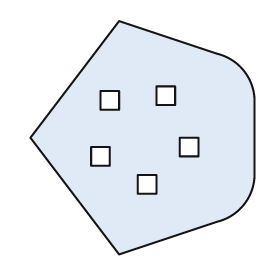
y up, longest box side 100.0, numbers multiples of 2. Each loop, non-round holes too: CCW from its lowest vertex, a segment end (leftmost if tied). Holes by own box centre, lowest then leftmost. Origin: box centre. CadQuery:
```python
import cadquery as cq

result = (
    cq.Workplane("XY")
    .moveTo(-10.0, -50.0)
    .lineTo(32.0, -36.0)
    .threePointArc((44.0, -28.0), (48.0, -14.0))
    .lineTo(48.0, 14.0)
    .threePointArc((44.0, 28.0), (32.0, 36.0))
    .lineTo(-10.0, 50.0)
    .lineTo(-48.0, 0.0)
    .close()
    .moveTo(-2.0, -24.0)
    .lineTo(6.0, -24.0)
    .lineTo(6.0, -16.0)
    .lineTo(-2.0, -16.0)
    .close()
    .moveTo(-22.0, -12.0)
    .lineTo(-14.0, -12.0)
    .lineTo(-14.0, -4.0)
    .lineTo(-22.0, -4.0)
    .close()
    .moveTo(16.0, -8.0)
    .lineTo(24.0, -8.0)
    .lineTo(24.0, 0.0)
    .lineTo(16.0, 0.0)
    .close()
    .moveTo(-18.0, 12.0)
    .lineTo(-10.0, 12.0)
    .lineTo(-10.0, 20.0)
    .lineTo(-18.0, 20.0)
    .close()
    .moveTo(6.0, 14.0)
    .lineTo(14.0, 14.0)
    .lineTo(14.0, 22.0)
    .lineTo(6.0, 22.0)
    .close()
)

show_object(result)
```